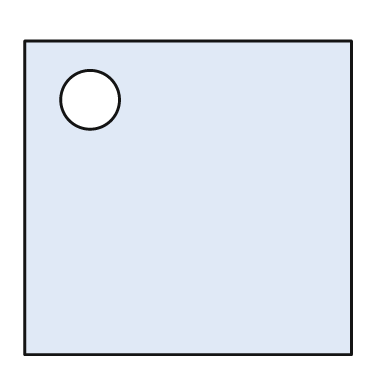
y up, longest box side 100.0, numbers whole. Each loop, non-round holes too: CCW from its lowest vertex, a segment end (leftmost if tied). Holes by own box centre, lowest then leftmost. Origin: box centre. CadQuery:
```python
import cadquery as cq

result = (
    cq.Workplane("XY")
    .moveTo(-50.0, -48.0)
    .lineTo(50.0, -48.0)
    .lineTo(50.0, 48.0)
    .lineTo(-50.0, 48.0)
    .close()
    .moveTo(-30.0, 30.0)
    .circle(9.0)
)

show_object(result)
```